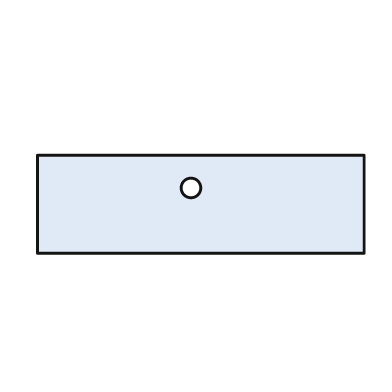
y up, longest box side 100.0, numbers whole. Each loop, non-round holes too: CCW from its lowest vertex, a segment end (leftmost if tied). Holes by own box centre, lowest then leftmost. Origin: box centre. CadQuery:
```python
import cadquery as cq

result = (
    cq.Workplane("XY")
    .moveTo(-50.0, -15.0)
    .lineTo(50.0, -15.0)
    .lineTo(50.0, 15.0)
    .lineTo(-50.0, 15.0)
    .close()
    .moveTo(-3.0, 5.0)
    .circle(3.0)
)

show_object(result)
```